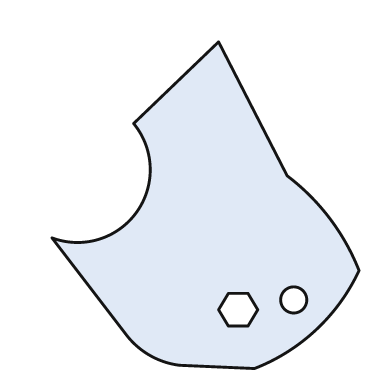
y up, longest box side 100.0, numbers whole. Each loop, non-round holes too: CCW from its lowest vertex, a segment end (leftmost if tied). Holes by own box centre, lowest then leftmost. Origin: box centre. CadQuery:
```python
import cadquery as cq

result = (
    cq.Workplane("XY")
    .moveTo(15.0, -50.0)
    .threePointArc((34.0, -38.0), (47.0, -20.0))
    .threePointArc((38.0, -4.0), (25.0, 9.0))
    .lineTo(4.0, 50.0)
    .lineTo(-22.0, 25.0)
    .threePointArc((-21.0, -2.0), (-47.0, -10.0))
    .lineTo(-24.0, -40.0)
    .threePointArc((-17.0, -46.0), (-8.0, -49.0))
    .close()
    .moveTo(7.0, -37.0)
    .lineTo(13.0, -37.0)
    .lineTo(16.0, -32.0)
    .lineTo(13.0, -27.0)
    .lineTo(7.0, -27.0)
    .lineTo(4.0, -32.0)
    .close()
    .moveTo(27.0, -29.0)
    .circle(4.0)
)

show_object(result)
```